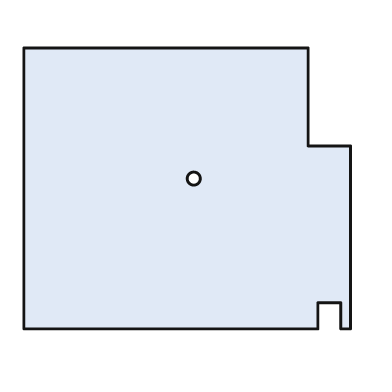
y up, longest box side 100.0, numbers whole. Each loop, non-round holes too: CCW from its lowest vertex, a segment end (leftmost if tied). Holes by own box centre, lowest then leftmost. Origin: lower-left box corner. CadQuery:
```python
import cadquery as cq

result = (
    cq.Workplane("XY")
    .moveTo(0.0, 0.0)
    .lineTo(90.0, 0.0)
    .lineTo(90.0, 8.0)
    .lineTo(97.0, 8.0)
    .lineTo(97.0, 0.0)
    .lineTo(100.0, 0.0)
    .lineTo(100.0, 56.0)
    .lineTo(87.0, 56.0)
    .lineTo(87.0, 86.0)
    .lineTo(0.0, 86.0)
    .close()
    .moveTo(52.0, 46.0)
    .circle(2.0)
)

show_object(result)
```